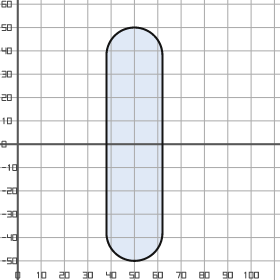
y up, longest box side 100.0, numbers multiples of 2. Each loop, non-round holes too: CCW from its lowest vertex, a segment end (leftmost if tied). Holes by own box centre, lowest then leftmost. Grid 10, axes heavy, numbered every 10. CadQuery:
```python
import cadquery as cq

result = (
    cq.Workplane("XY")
    .moveTo(38.0, -38.0)
    .threePointArc((50.0, -50.0), (62.0, -38.0))
    .lineTo(62.0, 38.0)
    .threePointArc((50.0, 50.0), (38.0, 38.0))
    .close()
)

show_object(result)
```